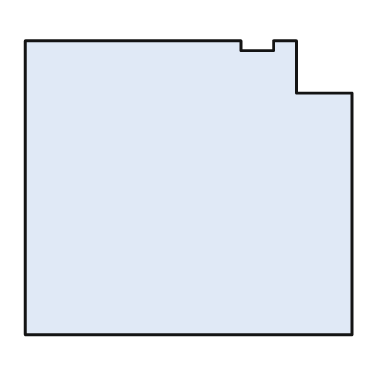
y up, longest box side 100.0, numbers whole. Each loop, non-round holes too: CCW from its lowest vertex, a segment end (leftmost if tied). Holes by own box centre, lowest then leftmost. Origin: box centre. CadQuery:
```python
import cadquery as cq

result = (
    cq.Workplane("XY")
    .moveTo(-50.0, -45.0)
    .lineTo(50.0, -45.0)
    .lineTo(50.0, 29.0)
    .lineTo(33.0, 29.0)
    .lineTo(33.0, 45.0)
    .lineTo(26.0, 45.0)
    .lineTo(26.0, 42.0)
    .lineTo(16.0, 42.0)
    .lineTo(16.0, 45.0)
    .lineTo(-50.0, 45.0)
    .close()
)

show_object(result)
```